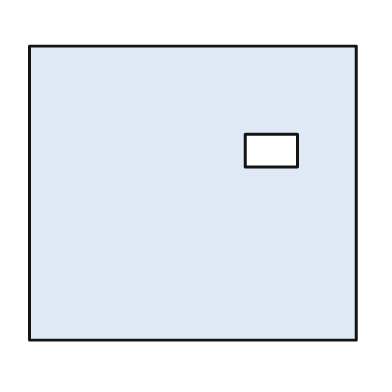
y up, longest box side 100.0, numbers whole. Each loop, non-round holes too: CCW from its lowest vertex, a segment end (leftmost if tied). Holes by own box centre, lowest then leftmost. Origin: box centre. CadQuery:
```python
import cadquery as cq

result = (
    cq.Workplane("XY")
    .moveTo(-50.0, -45.0)
    .lineTo(50.0, -45.0)
    .lineTo(50.0, 45.0)
    .lineTo(-50.0, 45.0)
    .close()
    .moveTo(16.0, 8.0)
    .lineTo(32.0, 8.0)
    .lineTo(32.0, 18.0)
    .lineTo(16.0, 18.0)
    .close()
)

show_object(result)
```